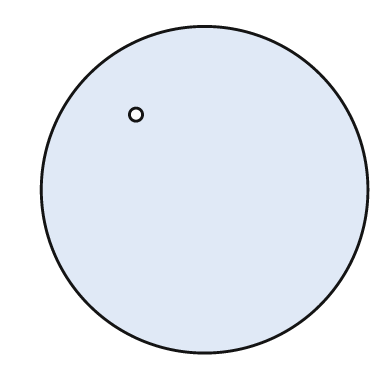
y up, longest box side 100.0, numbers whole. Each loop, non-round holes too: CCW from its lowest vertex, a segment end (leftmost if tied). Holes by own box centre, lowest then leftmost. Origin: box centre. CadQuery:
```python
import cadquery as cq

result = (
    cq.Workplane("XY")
    .moveTo(0.0, 0.0)
    .circle(50.0)
    .moveTo(-21.0, 23.0)
    .circle(2.0)
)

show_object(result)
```